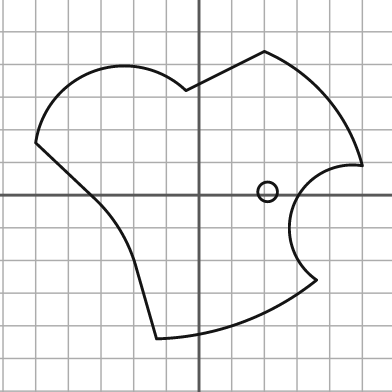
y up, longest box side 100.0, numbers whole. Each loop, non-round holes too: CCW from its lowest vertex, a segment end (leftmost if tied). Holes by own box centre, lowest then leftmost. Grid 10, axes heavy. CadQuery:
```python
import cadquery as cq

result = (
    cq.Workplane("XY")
    .moveTo(-13.0, -44.0)
    .threePointArc((13.0, -39.0), (36.0, -26.0))
    .threePointArc((29.0, -3.0), (50.0, 9.0))
    .threePointArc((39.0, 30.0), (20.0, 44.0))
    .lineTo(-4.0, 32.0)
    .threePointArc((-32.0, 38.0), (-50.0, 16.0))
    .lineTo(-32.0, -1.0)
    .threePointArc((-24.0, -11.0), (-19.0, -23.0))
    .close()
    .moveTo(21.0, 1.0)
    .circle(3.0)
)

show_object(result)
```